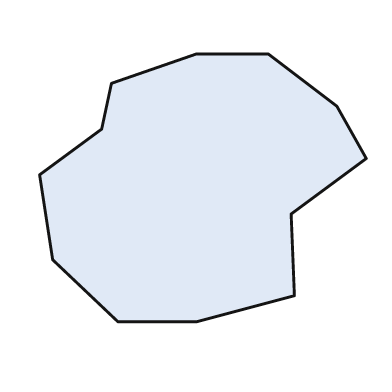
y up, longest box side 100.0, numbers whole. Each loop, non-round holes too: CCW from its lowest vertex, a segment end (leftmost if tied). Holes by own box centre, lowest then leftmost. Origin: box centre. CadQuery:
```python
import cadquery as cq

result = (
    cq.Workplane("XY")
    .moveTo(-26.0, -41.0)
    .lineTo(-2.0, -41.0)
    .lineTo(28.0, -33.0)
    .lineTo(27.0, -8.0)
    .lineTo(50.0, 9.0)
    .lineTo(41.0, 25.0)
    .lineTo(20.0, 41.0)
    .lineTo(-2.0, 41.0)
    .lineTo(-28.0, 32.0)
    .lineTo(-31.0, 18.0)
    .lineTo(-50.0, 4.0)
    .lineTo(-46.0, -22.0)
    .close()
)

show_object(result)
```